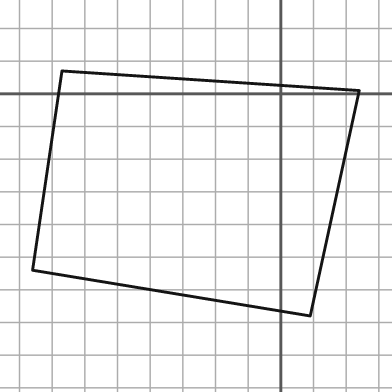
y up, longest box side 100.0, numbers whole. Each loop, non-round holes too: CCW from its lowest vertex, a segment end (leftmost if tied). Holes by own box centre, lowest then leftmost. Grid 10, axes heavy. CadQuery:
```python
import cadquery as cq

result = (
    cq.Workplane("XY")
    .moveTo(9.0, -68.0)
    .lineTo(24.0, 1.0)
    .lineTo(-67.0, 7.0)
    .lineTo(-76.0, -54.0)
    .close()
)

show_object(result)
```